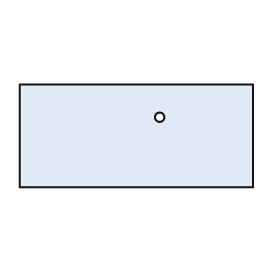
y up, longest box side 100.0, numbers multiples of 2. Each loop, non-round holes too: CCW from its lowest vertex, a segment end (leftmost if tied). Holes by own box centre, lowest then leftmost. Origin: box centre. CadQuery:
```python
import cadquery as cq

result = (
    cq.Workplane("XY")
    .moveTo(-50.0, -22.0)
    .lineTo(50.0, -22.0)
    .lineTo(50.0, 22.0)
    .lineTo(-50.0, 22.0)
    .close()
    .moveTo(10.0, 8.0)
    .circle(2.0)
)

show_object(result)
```